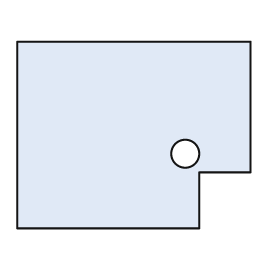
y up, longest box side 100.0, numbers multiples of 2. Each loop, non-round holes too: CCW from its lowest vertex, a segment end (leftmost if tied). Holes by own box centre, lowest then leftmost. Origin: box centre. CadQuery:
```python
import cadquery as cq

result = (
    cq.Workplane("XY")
    .moveTo(-50.0, -40.0)
    .lineTo(28.0, -40.0)
    .lineTo(28.0, -16.0)
    .lineTo(50.0, -16.0)
    .lineTo(50.0, 40.0)
    .lineTo(-50.0, 40.0)
    .close()
    .moveTo(22.0, -8.0)
    .circle(6.0)
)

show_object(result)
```